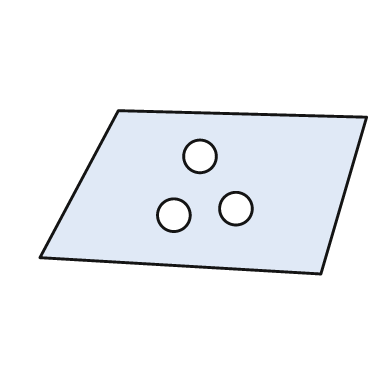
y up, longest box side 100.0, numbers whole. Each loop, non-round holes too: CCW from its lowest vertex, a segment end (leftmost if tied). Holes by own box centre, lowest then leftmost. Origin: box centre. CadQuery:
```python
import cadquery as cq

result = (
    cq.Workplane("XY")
    .moveTo(36.0, -25.0)
    .lineTo(50.0, 23.0)
    .lineTo(-26.0, 25.0)
    .lineTo(-50.0, -20.0)
    .close()
    .moveTo(-9.0, -7.0)
    .circle(5.0)
    .moveTo(10.0, -5.0)
    .circle(5.0)
    .moveTo(-1.0, 11.0)
    .circle(5.0)
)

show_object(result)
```